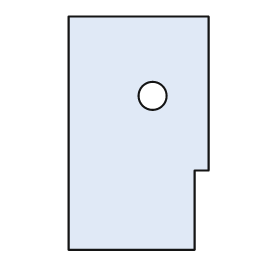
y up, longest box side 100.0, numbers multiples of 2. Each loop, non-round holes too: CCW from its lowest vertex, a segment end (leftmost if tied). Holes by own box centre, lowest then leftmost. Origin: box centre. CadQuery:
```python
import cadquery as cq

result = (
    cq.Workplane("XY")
    .moveTo(-30.0, -50.0)
    .lineTo(24.0, -50.0)
    .lineTo(24.0, -16.0)
    .lineTo(30.0, -16.0)
    .lineTo(30.0, 50.0)
    .lineTo(-30.0, 50.0)
    .close()
    .moveTo(6.0, 16.0)
    .circle(6.0)
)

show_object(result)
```